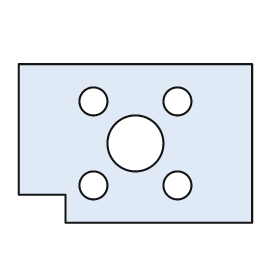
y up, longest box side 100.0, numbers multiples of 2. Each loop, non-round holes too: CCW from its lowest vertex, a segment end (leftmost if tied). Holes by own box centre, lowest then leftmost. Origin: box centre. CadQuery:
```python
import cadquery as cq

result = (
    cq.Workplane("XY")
    .moveTo(-30.0, -34.0)
    .lineTo(50.0, -34.0)
    .lineTo(50.0, 34.0)
    .lineTo(-50.0, 34.0)
    .lineTo(-50.0, -22.0)
    .lineTo(-30.0, -22.0)
    .close()
    .moveTo(-18.0, -18.0)
    .circle(6.0)
    .moveTo(18.0, -18.0)
    .circle(6.0)
    .moveTo(0.0, 0.0)
    .circle(12.0)
    .moveTo(-18.0, 18.0)
    .circle(6.0)
    .moveTo(18.0, 18.0)
    .circle(6.0)
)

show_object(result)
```